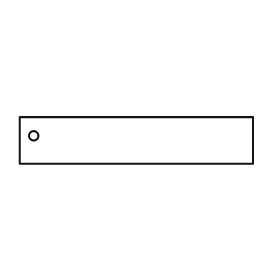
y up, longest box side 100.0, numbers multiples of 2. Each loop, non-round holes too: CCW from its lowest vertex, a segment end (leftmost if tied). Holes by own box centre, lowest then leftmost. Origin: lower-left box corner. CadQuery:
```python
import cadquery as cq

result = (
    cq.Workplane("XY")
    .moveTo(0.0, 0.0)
    .lineTo(100.0, 0.0)
    .lineTo(100.0, 20.0)
    .lineTo(0.0, 20.0)
    .close()
    .moveTo(6.0, 12.0)
    .circle(2.0)
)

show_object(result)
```